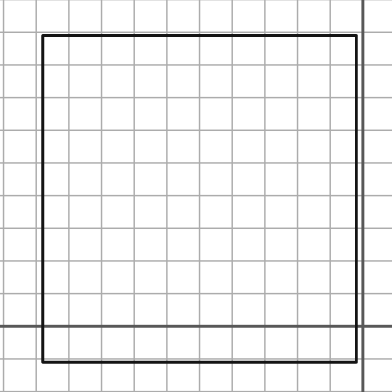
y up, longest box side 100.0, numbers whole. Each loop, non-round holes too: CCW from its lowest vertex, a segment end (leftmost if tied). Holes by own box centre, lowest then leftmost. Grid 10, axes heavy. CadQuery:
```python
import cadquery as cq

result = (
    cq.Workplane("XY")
    .moveTo(-98.0, -11.0)
    .lineTo(-2.0, -11.0)
    .lineTo(-2.0, 89.0)
    .lineTo(-98.0, 89.0)
    .close()
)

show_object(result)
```